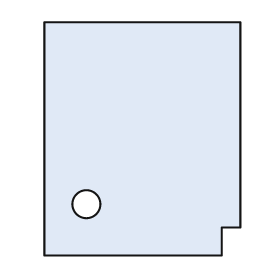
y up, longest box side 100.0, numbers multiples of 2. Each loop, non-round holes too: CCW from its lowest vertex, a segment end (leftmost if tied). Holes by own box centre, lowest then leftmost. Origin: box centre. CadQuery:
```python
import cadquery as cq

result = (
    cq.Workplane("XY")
    .moveTo(-42.0, -50.0)
    .lineTo(34.0, -50.0)
    .lineTo(34.0, -38.0)
    .lineTo(42.0, -38.0)
    .lineTo(42.0, 50.0)
    .lineTo(-42.0, 50.0)
    .close()
    .moveTo(-24.0, -28.0)
    .circle(6.0)
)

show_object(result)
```